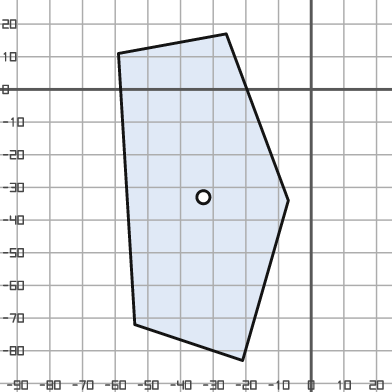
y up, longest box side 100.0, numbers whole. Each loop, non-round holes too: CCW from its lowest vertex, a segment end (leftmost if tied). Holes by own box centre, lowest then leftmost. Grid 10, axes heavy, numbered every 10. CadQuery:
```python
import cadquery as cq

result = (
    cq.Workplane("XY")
    .moveTo(-21.0, -83.0)
    .lineTo(-7.0, -34.0)
    .lineTo(-26.0, 17.0)
    .lineTo(-59.0, 11.0)
    .lineTo(-54.0, -72.0)
    .close()
    .moveTo(-33.0, -33.0)
    .circle(2.0)
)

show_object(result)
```